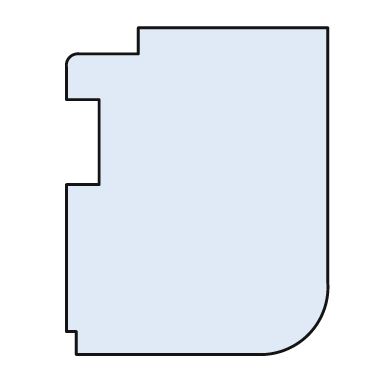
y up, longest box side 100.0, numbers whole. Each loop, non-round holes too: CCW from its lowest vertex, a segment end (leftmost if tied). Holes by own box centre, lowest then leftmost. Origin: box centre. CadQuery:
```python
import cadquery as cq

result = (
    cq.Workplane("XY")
    .moveTo(-37.0, -50.0)
    .lineTo(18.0, -50.0)
    .threePointArc((34.0, -44.0), (40.0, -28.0))
    .lineTo(40.0, 50.0)
    .lineTo(-18.0, 50.0)
    .lineTo(-18.0, 42.0)
    .lineTo(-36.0, 42.0)
    .threePointArc((-39.0, 41.0), (-40.0, 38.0))
    .lineTo(-40.0, 28.0)
    .lineTo(-30.0, 28.0)
    .lineTo(-30.0, 2.0)
    .lineTo(-40.0, 2.0)
    .lineTo(-40.0, -43.0)
    .lineTo(-37.0, -43.0)
    .close()
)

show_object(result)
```